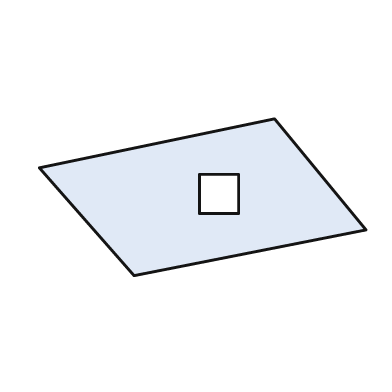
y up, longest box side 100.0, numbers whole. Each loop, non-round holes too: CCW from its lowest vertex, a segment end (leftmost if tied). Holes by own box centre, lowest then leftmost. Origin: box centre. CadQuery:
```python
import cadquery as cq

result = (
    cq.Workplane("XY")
    .moveTo(-21.0, -24.0)
    .lineTo(50.0, -10.0)
    .lineTo(22.0, 24.0)
    .lineTo(-50.0, 9.0)
    .close()
    .moveTo(-1.0, -5.0)
    .lineTo(11.0, -5.0)
    .lineTo(11.0, 7.0)
    .lineTo(-1.0, 7.0)
    .close()
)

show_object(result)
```